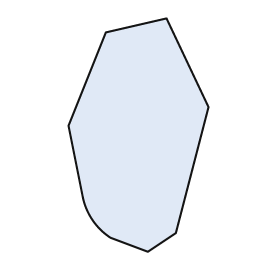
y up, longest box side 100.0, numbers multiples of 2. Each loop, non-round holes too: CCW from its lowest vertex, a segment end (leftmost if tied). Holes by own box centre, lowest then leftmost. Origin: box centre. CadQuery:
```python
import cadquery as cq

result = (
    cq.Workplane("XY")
    .moveTo(4.0, -50.0)
    .lineTo(16.0, -42.0)
    .lineTo(30.0, 12.0)
    .lineTo(12.0, 50.0)
    .lineTo(-14.0, 44.0)
    .lineTo(-30.0, 4.0)
    .lineTo(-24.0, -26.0)
    .threePointArc((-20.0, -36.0), (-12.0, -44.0))
    .close()
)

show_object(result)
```